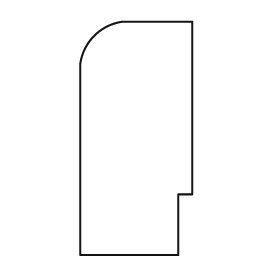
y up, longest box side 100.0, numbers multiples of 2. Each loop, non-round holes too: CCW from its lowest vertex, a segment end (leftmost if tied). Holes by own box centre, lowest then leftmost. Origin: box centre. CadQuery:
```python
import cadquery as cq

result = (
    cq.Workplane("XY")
    .moveTo(-24.0, -50.0)
    .lineTo(18.0, -50.0)
    .lineTo(18.0, -24.0)
    .lineTo(24.0, -24.0)
    .lineTo(24.0, 50.0)
    .lineTo(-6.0, 50.0)
    .threePointArc((-18.0, 44.0), (-24.0, 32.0))
    .close()
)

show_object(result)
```